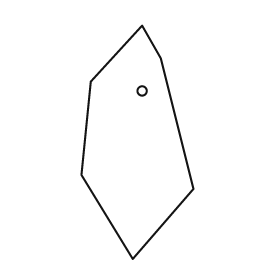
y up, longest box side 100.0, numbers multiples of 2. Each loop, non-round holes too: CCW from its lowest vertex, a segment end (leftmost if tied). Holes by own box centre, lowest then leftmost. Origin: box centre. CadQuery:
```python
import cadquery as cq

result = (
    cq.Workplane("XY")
    .moveTo(-2.0, -50.0)
    .lineTo(24.0, -20.0)
    .lineTo(10.0, 36.0)
    .lineTo(2.0, 50.0)
    .lineTo(-20.0, 26.0)
    .lineTo(-24.0, -14.0)
    .close()
    .moveTo(2.0, 22.0)
    .circle(2.0)
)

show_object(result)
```